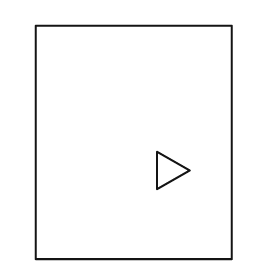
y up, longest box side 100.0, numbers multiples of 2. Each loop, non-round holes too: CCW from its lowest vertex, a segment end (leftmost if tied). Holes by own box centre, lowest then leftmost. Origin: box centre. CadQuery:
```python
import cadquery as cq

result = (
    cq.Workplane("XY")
    .moveTo(-42.0, -50.0)
    .lineTo(42.0, -50.0)
    .lineTo(42.0, 50.0)
    .lineTo(-42.0, 50.0)
    .close()
    .moveTo(10.0, -20.0)
    .lineTo(24.0, -12.0)
    .lineTo(10.0, -4.0)
    .close()
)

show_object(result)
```